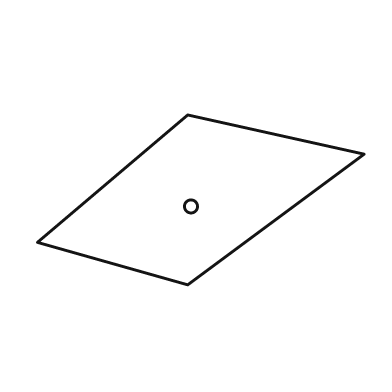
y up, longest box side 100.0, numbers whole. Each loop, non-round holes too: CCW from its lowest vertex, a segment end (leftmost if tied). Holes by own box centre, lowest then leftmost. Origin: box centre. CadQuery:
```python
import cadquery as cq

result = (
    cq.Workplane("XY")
    .moveTo(-4.0, -26.0)
    .lineTo(50.0, 14.0)
    .lineTo(-4.0, 26.0)
    .lineTo(-50.0, -13.0)
    .close()
    .moveTo(-3.0, -2.0)
    .circle(2.0)
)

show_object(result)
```